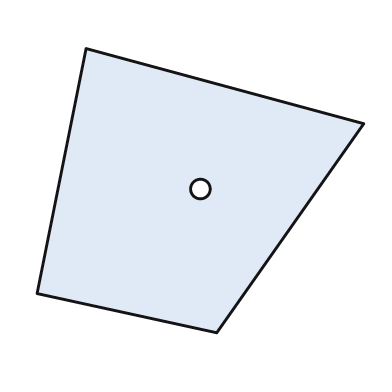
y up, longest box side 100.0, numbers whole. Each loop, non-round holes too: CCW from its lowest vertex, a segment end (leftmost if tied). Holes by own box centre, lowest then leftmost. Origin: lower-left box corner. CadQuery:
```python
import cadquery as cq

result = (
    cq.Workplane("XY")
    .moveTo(55.0, 0.0)
    .lineTo(100.0, 64.0)
    .lineTo(15.0, 87.0)
    .lineTo(0.0, 12.0)
    .close()
    .moveTo(50.0, 44.0)
    .circle(3.0)
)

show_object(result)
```